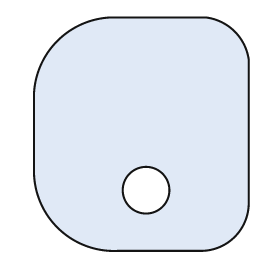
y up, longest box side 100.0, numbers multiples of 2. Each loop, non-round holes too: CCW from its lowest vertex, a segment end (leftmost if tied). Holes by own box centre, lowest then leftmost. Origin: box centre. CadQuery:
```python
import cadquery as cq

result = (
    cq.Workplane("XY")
    .moveTo(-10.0, -50.0)
    .lineTo(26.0, -50.0)
    .threePointArc((40.0, -44.0), (46.0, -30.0))
    .lineTo(46.0, 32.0)
    .threePointArc((40.0, 44.0), (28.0, 50.0))
    .lineTo(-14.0, 50.0)
    .threePointArc((-36.0, 40.0), (-46.0, 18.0))
    .lineTo(-46.0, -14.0)
    .threePointArc((-36.0, -40.0), (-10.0, -50.0))
    .close()
    .moveTo(2.0, -24.0)
    .circle(10.0)
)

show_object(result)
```